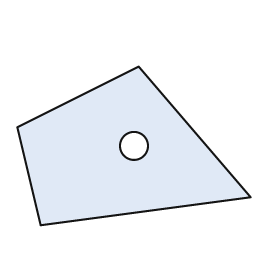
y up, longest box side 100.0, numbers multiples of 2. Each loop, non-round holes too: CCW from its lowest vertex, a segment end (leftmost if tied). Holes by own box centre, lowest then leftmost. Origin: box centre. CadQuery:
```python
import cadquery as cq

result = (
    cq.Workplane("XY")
    .moveTo(-40.0, -34.0)
    .lineTo(50.0, -22.0)
    .lineTo(2.0, 34.0)
    .lineTo(-50.0, 8.0)
    .close()
    .moveTo(0.0, 0.0)
    .circle(6.0)
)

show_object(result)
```